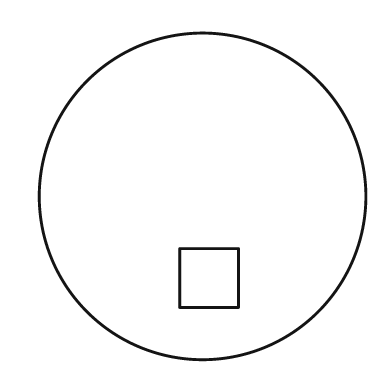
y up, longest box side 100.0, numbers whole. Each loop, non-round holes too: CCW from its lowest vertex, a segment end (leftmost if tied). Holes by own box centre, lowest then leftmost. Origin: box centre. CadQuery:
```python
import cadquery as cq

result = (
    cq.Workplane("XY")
    .moveTo(0.0, 0.0)
    .circle(50.0)
    .moveTo(-7.0, -34.0)
    .lineTo(11.0, -34.0)
    .lineTo(11.0, -16.0)
    .lineTo(-7.0, -16.0)
    .close()
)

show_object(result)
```